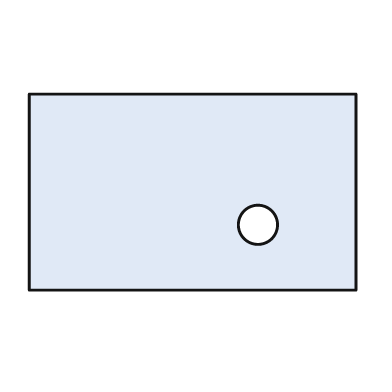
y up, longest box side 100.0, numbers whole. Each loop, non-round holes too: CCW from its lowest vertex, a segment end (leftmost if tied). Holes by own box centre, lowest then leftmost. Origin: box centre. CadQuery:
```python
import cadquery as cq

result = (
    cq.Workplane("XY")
    .moveTo(-50.0, -30.0)
    .lineTo(50.0, -30.0)
    .lineTo(50.0, 30.0)
    .lineTo(-50.0, 30.0)
    .close()
    .moveTo(20.0, -10.0)
    .circle(6.0)
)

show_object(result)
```